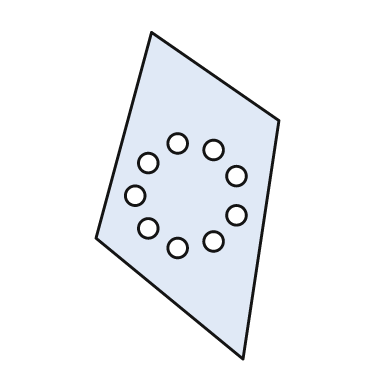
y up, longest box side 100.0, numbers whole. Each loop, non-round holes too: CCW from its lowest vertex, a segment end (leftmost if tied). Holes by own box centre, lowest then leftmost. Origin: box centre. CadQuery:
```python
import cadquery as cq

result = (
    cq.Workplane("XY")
    .moveTo(17.0, -50.0)
    .lineTo(28.0, 23.0)
    .lineTo(-11.0, 50.0)
    .lineTo(-28.0, -13.0)
    .close()
    .moveTo(-3.0, -16.0)
    .circle(3.0)
    .moveTo(8.0, -14.0)
    .circle(3.0)
    .moveTo(-12.0, -10.0)
    .circle(3.0)
    .moveTo(15.0, -6.0)
    .circle(3.0)
    .moveTo(-16.0, 0.0)
    .circle(3.0)
    .moveTo(15.0, 6.0)
    .circle(3.0)
    .moveTo(-12.0, 10.0)
    .circle(3.0)
    .moveTo(8.0, 14.0)
    .circle(3.0)
    .moveTo(-3.0, 16.0)
    .circle(3.0)
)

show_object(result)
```